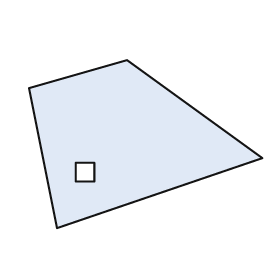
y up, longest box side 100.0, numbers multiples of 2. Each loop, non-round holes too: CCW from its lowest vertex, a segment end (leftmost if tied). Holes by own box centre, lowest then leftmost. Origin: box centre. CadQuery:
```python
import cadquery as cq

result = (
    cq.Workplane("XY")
    .moveTo(-38.0, -36.0)
    .lineTo(50.0, -6.0)
    .lineTo(-8.0, 36.0)
    .lineTo(-50.0, 24.0)
    .close()
    .moveTo(-30.0, -16.0)
    .lineTo(-22.0, -16.0)
    .lineTo(-22.0, -8.0)
    .lineTo(-30.0, -8.0)
    .close()
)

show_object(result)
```